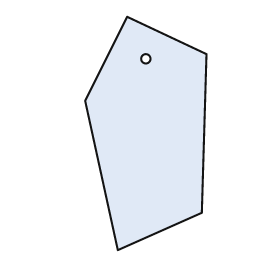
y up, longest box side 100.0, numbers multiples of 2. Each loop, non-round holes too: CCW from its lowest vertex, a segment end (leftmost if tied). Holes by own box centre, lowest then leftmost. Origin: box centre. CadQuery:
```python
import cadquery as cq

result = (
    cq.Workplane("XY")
    .moveTo(-12.0, -50.0)
    .lineTo(24.0, -34.0)
    .lineTo(26.0, 34.0)
    .lineTo(-8.0, 50.0)
    .lineTo(-26.0, 14.0)
    .close()
    .moveTo(0.0, 32.0)
    .circle(2.0)
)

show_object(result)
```